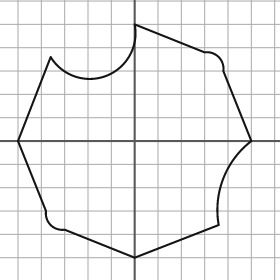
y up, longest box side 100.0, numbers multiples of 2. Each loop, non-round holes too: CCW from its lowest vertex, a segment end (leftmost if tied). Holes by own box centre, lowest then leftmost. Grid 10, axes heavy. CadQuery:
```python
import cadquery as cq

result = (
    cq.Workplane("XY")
    .moveTo(0.0, -50.0)
    .lineTo(36.0, -36.0)
    .threePointArc((38.0, -16.0), (50.0, 0.0))
    .lineTo(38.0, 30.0)
    .threePointArc((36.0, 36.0), (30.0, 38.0))
    .lineTo(0.0, 50.0)
    .threePointArc((-12.0, 28.0), (-36.0, 36.0))
    .lineTo(-50.0, 0.0)
    .lineTo(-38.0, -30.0)
    .threePointArc((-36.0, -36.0), (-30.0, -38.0))
    .close()
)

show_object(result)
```